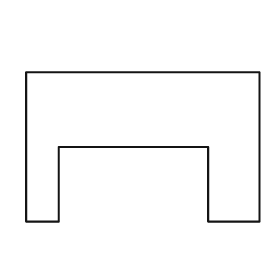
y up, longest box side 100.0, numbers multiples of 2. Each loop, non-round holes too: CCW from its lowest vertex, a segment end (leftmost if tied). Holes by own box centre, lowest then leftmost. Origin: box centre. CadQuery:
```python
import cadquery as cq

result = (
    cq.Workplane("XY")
    .moveTo(-50.0, -32.0)
    .lineTo(-36.0, -32.0)
    .lineTo(-36.0, 0.0)
    .lineTo(28.0, 0.0)
    .lineTo(28.0, -32.0)
    .lineTo(50.0, -32.0)
    .lineTo(50.0, 32.0)
    .lineTo(-50.0, 32.0)
    .close()
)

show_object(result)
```